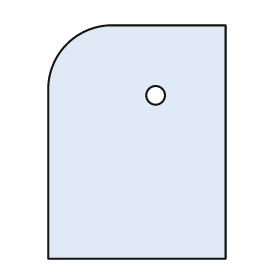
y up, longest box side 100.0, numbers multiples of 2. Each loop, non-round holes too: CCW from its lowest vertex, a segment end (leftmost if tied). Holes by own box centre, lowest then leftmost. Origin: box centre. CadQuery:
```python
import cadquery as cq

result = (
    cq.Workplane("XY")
    .moveTo(-38.0, -50.0)
    .lineTo(38.0, -50.0)
    .lineTo(38.0, 50.0)
    .lineTo(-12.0, 50.0)
    .threePointArc((-30.0, 42.0), (-38.0, 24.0))
    .close()
    .moveTo(8.0, 20.0)
    .circle(4.0)
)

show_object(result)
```